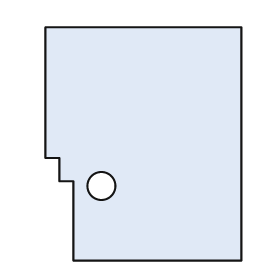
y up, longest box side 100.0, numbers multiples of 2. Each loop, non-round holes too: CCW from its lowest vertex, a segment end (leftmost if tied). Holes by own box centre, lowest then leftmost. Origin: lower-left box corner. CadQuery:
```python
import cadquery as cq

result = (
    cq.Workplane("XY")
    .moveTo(12.0, 0.0)
    .lineTo(84.0, 0.0)
    .lineTo(84.0, 100.0)
    .lineTo(0.0, 100.0)
    .lineTo(0.0, 44.0)
    .lineTo(6.0, 44.0)
    .lineTo(6.0, 34.0)
    .lineTo(12.0, 34.0)
    .close()
    .moveTo(24.0, 32.0)
    .circle(6.0)
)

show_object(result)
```